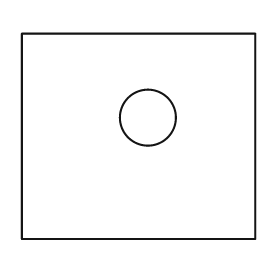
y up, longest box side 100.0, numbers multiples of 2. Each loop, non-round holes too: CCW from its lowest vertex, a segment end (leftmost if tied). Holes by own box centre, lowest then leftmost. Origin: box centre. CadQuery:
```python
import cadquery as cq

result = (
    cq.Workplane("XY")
    .moveTo(-50.0, -44.0)
    .lineTo(50.0, -44.0)
    .lineTo(50.0, 44.0)
    .lineTo(-50.0, 44.0)
    .close()
    .moveTo(4.0, 8.0)
    .circle(12.0)
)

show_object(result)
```